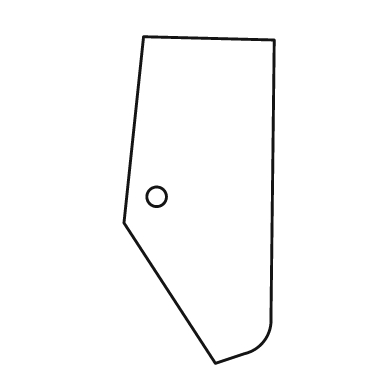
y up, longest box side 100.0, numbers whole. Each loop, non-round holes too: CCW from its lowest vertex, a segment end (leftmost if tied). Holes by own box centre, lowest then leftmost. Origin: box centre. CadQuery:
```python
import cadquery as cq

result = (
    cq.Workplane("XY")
    .moveTo(5.0, -50.0)
    .lineTo(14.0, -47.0)
    .threePointArc((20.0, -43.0), (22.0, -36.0))
    .lineTo(23.0, 49.0)
    .lineTo(-17.0, 50.0)
    .lineTo(-23.0, -7.0)
    .close()
    .moveTo(-13.0, 1.0)
    .circle(3.0)
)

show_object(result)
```